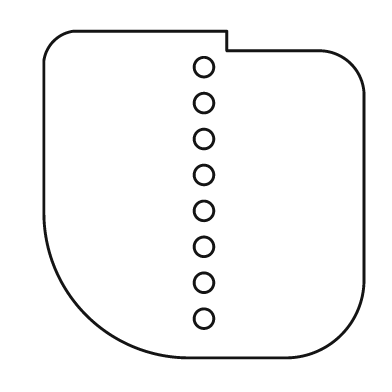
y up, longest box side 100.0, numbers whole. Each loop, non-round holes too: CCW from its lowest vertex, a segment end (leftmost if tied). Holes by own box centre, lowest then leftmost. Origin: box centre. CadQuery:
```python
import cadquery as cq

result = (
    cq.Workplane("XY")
    .moveTo(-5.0, -50.0)
    .lineTo(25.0, -50.0)
    .threePointArc((42.0, -43.0), (49.0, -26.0))
    .lineTo(49.0, 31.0)
    .threePointArc((45.0, 40.0), (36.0, 44.0))
    .lineTo(7.0, 44.0)
    .lineTo(7.0, 50.0)
    .lineTo(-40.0, 50.0)
    .threePointArc((-46.0, 47.0), (-49.0, 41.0))
    .lineTo(-49.0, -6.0)
    .threePointArc((-36.0, -37.0), (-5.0, -50.0))
    .close()
    .moveTo(0.0, -38.0)
    .circle(3.0)
    .moveTo(0.0, -27.0)
    .circle(3.0)
    .moveTo(0.0, -16.0)
    .circle(3.0)
    .moveTo(0.0, -5.0)
    .circle(3.0)
    .moveTo(0.0, 6.0)
    .circle(3.0)
    .moveTo(0.0, 17.0)
    .circle(3.0)
    .moveTo(0.0, 28.0)
    .circle(3.0)
    .moveTo(0.0, 39.0)
    .circle(3.0)
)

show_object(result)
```